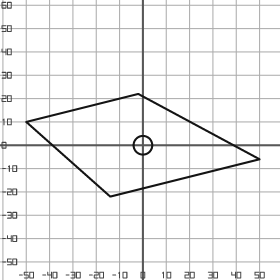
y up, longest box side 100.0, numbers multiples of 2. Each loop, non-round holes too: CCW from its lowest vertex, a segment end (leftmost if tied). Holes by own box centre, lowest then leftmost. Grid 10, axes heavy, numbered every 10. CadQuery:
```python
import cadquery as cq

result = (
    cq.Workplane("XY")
    .moveTo(-14.0, -22.0)
    .lineTo(50.0, -6.0)
    .lineTo(-2.0, 22.0)
    .lineTo(-50.0, 10.0)
    .close()
    .moveTo(0.0, 0.0)
    .circle(4.0)
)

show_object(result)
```